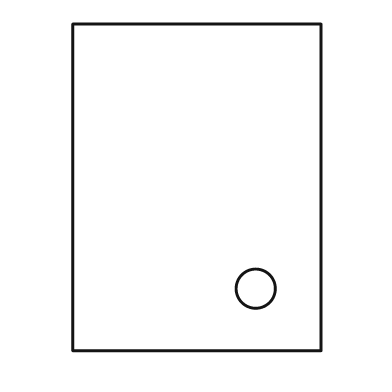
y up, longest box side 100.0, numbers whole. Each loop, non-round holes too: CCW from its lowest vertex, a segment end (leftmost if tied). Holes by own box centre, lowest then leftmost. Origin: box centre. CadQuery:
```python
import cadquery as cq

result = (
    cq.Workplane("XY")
    .moveTo(-38.0, -50.0)
    .lineTo(38.0, -50.0)
    .lineTo(38.0, 50.0)
    .lineTo(-38.0, 50.0)
    .close()
    .moveTo(18.0, -31.0)
    .circle(6.0)
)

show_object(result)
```